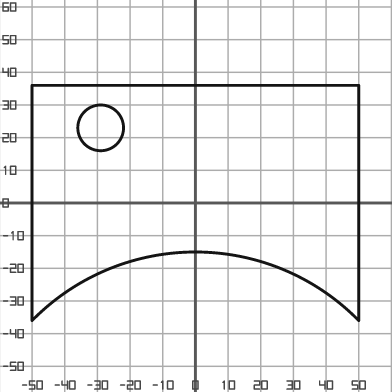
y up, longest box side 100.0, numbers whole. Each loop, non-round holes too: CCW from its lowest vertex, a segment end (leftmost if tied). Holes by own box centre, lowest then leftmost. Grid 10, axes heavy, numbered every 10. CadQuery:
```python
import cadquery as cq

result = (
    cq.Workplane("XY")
    .moveTo(-50.0, -36.0)
    .threePointArc((0.0, -15.0), (50.0, -36.0))
    .lineTo(50.0, 36.0)
    .lineTo(-50.0, 36.0)
    .close()
    .moveTo(-29.0, 23.0)
    .circle(7.0)
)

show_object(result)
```